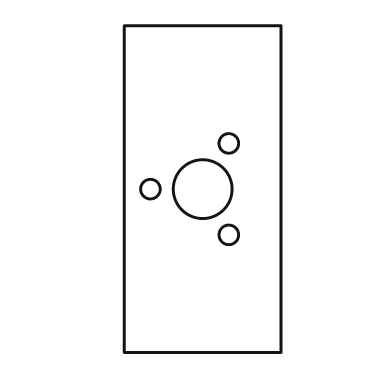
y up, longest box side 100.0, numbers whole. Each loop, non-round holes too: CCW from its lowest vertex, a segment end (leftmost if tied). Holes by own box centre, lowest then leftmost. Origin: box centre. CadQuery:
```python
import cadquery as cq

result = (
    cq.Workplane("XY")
    .moveTo(-24.0, -50.0)
    .lineTo(24.0, -50.0)
    .lineTo(24.0, 50.0)
    .lineTo(-24.0, 50.0)
    .close()
    .moveTo(8.0, -14.0)
    .circle(3.0)
    .moveTo(-16.0, 0.0)
    .circle(3.0)
    .moveTo(0.0, 0.0)
    .circle(9.0)
    .moveTo(8.0, 14.0)
    .circle(3.0)
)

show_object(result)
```